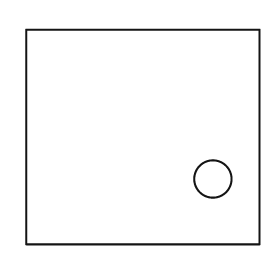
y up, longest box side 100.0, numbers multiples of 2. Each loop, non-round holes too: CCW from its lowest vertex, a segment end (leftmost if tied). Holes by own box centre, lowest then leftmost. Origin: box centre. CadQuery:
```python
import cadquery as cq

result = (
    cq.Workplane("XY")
    .moveTo(-50.0, -46.0)
    .lineTo(50.0, -46.0)
    .lineTo(50.0, 46.0)
    .lineTo(-50.0, 46.0)
    .close()
    .moveTo(30.0, -18.0)
    .circle(8.0)
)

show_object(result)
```